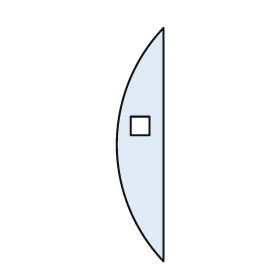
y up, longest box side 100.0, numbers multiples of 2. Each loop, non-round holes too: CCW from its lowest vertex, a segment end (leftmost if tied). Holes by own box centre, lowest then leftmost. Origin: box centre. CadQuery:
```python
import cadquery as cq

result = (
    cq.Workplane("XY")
    .moveTo(10.0, -50.0)
    .lineTo(10.0, 50.0)
    .threePointArc((-10.0, 0.0), (10.0, -50.0))
    .close()
    .moveTo(-4.0, 4.0)
    .lineTo(4.0, 4.0)
    .lineTo(4.0, 12.0)
    .lineTo(-4.0, 12.0)
    .close()
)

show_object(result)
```